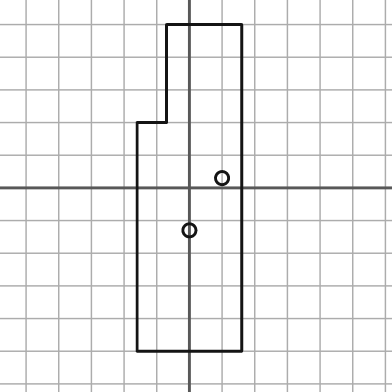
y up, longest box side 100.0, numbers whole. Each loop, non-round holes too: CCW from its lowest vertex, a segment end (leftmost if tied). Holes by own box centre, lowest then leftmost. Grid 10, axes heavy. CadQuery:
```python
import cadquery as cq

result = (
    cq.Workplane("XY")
    .moveTo(-16.0, -50.0)
    .lineTo(16.0, -50.0)
    .lineTo(16.0, 50.0)
    .lineTo(-7.0, 50.0)
    .lineTo(-7.0, 20.0)
    .lineTo(-16.0, 20.0)
    .close()
    .moveTo(0.0, -13.0)
    .circle(2.0)
    .moveTo(10.0, 3.0)
    .circle(2.0)
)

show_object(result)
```